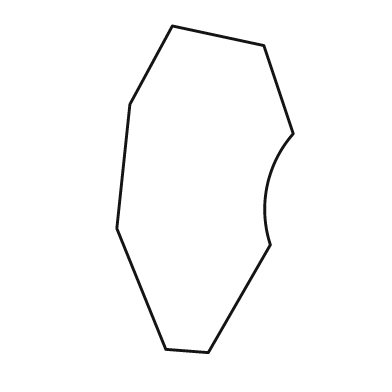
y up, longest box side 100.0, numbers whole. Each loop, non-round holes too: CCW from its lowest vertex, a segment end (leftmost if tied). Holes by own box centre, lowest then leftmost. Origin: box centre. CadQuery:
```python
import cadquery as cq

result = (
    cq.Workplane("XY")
    .moveTo(1.0, -50.0)
    .lineTo(20.0, -17.0)
    .threePointArc((19.0, 1.0), (27.0, 17.0))
    .lineTo(18.0, 44.0)
    .lineTo(-10.0, 50.0)
    .lineTo(-23.0, 26.0)
    .lineTo(-27.0, -12.0)
    .lineTo(-12.0, -49.0)
    .close()
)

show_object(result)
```